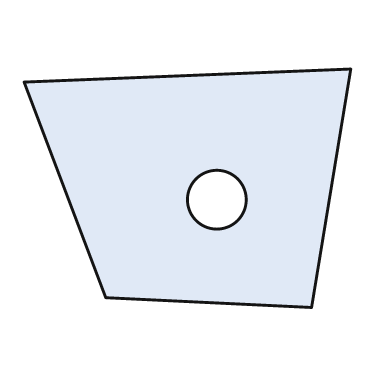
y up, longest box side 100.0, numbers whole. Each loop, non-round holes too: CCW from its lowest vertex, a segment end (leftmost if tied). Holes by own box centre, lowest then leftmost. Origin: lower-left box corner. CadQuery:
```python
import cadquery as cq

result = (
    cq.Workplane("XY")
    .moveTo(88.0, 0.0)
    .lineTo(100.0, 73.0)
    .lineTo(0.0, 69.0)
    .lineTo(25.0, 3.0)
    .close()
    .moveTo(59.0, 33.0)
    .circle(9.0)
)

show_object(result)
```